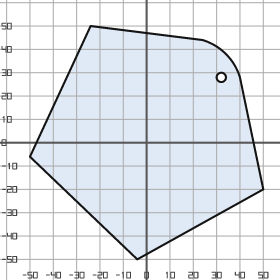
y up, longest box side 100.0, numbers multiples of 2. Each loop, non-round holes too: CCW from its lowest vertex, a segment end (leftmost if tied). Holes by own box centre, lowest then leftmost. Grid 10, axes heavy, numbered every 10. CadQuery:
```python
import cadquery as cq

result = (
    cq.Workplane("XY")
    .moveTo(-4.0, -50.0)
    .lineTo(50.0, -20.0)
    .lineTo(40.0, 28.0)
    .threePointArc((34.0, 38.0), (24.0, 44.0))
    .lineTo(-24.0, 50.0)
    .lineTo(-50.0, -6.0)
    .close()
    .moveTo(32.0, 28.0)
    .circle(2.0)
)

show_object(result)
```